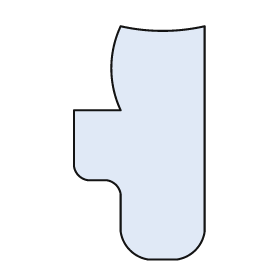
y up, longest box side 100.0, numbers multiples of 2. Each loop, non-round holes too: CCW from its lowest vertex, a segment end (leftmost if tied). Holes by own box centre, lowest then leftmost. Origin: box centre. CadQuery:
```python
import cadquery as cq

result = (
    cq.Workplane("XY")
    .moveTo(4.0, -50.0)
    .lineTo(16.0, -50.0)
    .threePointArc((24.0, -46.0), (28.0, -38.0))
    .lineTo(28.0, 50.0)
    .threePointArc((10.0, 48.0), (-8.0, 50.0))
    .threePointArc((-12.0, 32.0), (-8.0, 14.0))
    .lineTo(-28.0, 14.0)
    .lineTo(-28.0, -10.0)
    .threePointArc((-26.0, -14.0), (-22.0, -16.0))
    .lineTo(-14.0, -16.0)
    .threePointArc((-10.0, -18.0), (-8.0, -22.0))
    .lineTo(-8.0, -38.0)
    .threePointArc((-4.0, -46.0), (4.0, -50.0))
    .close()
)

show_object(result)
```